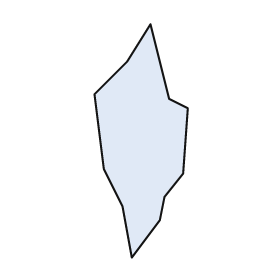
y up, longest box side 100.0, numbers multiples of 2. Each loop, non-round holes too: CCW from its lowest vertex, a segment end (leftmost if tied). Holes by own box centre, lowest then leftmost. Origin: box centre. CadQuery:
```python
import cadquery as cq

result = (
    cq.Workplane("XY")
    .moveTo(-4.0, -50.0)
    .lineTo(8.0, -34.0)
    .lineTo(10.0, -24.0)
    .lineTo(18.0, -14.0)
    .lineTo(20.0, 14.0)
    .lineTo(12.0, 18.0)
    .lineTo(4.0, 50.0)
    .lineTo(-6.0, 34.0)
    .lineTo(-20.0, 20.0)
    .lineTo(-16.0, -12.0)
    .lineTo(-8.0, -28.0)
    .close()
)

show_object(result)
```